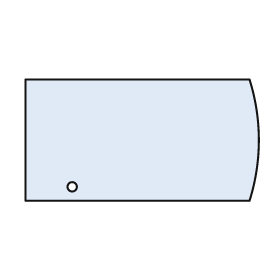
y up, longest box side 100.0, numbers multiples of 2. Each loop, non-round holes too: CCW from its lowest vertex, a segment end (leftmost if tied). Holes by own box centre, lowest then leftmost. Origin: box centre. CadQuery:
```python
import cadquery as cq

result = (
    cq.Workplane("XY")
    .moveTo(-50.0, -26.0)
    .lineTo(46.0, -26.0)
    .threePointArc((50.0, 0.0), (46.0, 26.0))
    .lineTo(-50.0, 26.0)
    .close()
    .moveTo(-30.0, -20.0)
    .circle(2.0)
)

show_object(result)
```